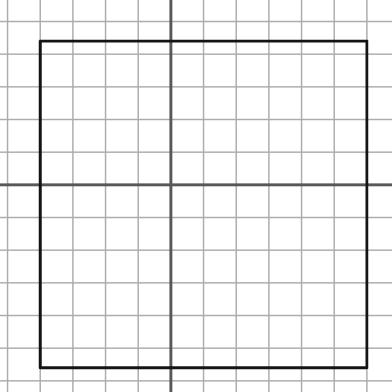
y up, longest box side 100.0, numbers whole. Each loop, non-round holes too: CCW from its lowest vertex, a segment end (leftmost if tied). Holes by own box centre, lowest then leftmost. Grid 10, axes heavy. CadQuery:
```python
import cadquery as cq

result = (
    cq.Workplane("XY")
    .moveTo(-40.0, -56.0)
    .lineTo(60.0, -56.0)
    .lineTo(60.0, 44.0)
    .lineTo(-40.0, 44.0)
    .close()
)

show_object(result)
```